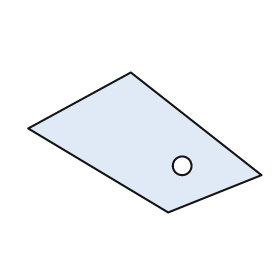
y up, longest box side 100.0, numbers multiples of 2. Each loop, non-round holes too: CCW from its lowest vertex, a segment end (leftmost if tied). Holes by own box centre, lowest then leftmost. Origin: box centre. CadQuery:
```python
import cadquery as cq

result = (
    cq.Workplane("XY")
    .moveTo(10.0, -30.0)
    .lineTo(50.0, -14.0)
    .lineTo(-6.0, 30.0)
    .lineTo(-50.0, 6.0)
    .close()
    .moveTo(16.0, -10.0)
    .circle(4.0)
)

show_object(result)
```